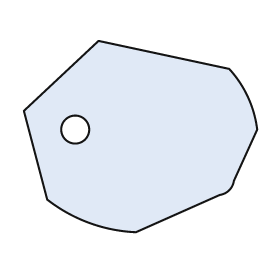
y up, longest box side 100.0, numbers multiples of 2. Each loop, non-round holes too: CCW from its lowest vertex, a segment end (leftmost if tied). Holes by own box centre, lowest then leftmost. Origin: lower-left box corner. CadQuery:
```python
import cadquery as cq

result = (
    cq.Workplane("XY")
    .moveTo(48.0, 0.0)
    .lineTo(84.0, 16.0)
    .threePointArc((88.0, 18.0), (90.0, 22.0))
    .lineTo(100.0, 44.0)
    .threePointArc((96.0, 58.0), (88.0, 70.0))
    .lineTo(32.0, 82.0)
    .lineTo(0.0, 52.0)
    .lineTo(10.0, 14.0)
    .threePointArc((28.0, 4.0), (48.0, 0.0))
    .close()
    .moveTo(22.0, 44.0)
    .circle(6.0)
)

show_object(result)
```